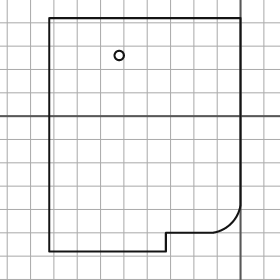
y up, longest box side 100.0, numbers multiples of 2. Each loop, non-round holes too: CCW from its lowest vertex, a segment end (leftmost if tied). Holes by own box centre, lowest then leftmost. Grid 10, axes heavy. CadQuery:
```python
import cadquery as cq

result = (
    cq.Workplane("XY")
    .moveTo(-82.0, -58.0)
    .lineTo(-32.0, -58.0)
    .lineTo(-32.0, -50.0)
    .lineTo(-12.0, -50.0)
    .threePointArc((-4.0, -46.0), (0.0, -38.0))
    .lineTo(0.0, 42.0)
    .lineTo(-82.0, 42.0)
    .close()
    .moveTo(-52.0, 26.0)
    .circle(2.0)
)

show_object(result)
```